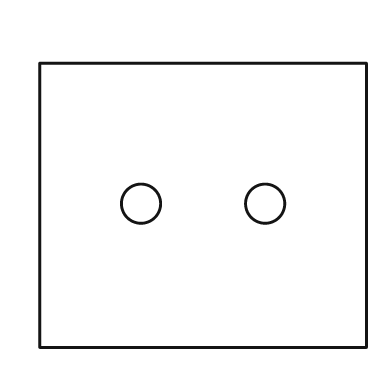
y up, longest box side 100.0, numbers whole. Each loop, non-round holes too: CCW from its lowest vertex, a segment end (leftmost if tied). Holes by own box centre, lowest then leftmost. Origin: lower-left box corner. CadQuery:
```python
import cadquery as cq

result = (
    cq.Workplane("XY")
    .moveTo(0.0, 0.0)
    .lineTo(100.0, 0.0)
    .lineTo(100.0, 87.0)
    .lineTo(0.0, 87.0)
    .close()
    .moveTo(31.0, 44.0)
    .circle(6.0)
    .moveTo(69.0, 44.0)
    .circle(6.0)
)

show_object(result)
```